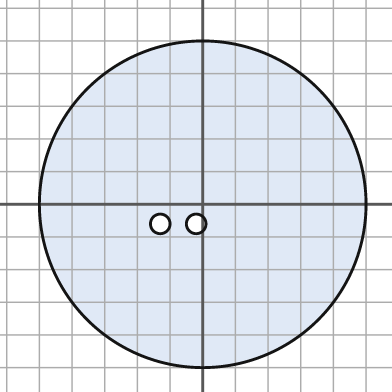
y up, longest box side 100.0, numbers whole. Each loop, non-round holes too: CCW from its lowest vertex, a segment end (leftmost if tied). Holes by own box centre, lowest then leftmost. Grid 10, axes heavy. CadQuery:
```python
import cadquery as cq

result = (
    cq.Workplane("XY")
    .moveTo(0.0, 0.0)
    .circle(50.0)
    .moveTo(-13.0, -6.0)
    .circle(3.0)
    .moveTo(-2.0, -6.0)
    .circle(3.0)
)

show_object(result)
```